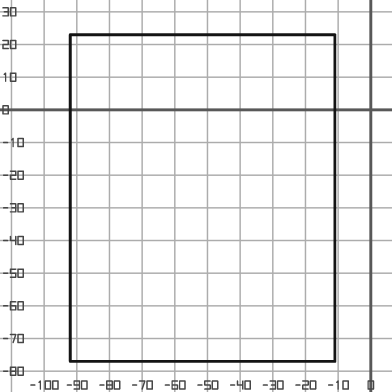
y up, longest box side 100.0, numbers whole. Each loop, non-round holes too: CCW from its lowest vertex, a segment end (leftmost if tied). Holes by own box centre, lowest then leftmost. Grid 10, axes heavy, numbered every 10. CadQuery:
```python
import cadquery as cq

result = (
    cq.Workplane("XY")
    .moveTo(-92.0, -77.0)
    .lineTo(-11.0, -77.0)
    .lineTo(-11.0, 23.0)
    .lineTo(-92.0, 23.0)
    .close()
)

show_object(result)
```